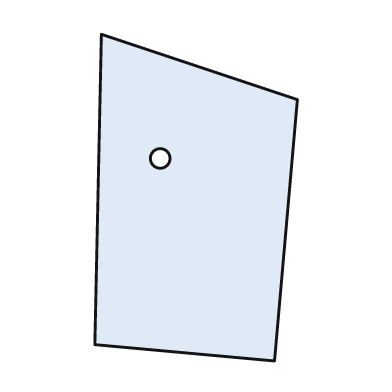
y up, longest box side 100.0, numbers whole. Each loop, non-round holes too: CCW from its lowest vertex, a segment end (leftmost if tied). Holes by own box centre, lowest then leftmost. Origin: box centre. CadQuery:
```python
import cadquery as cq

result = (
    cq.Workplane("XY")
    .moveTo(24.0, -50.0)
    .lineTo(31.0, 30.0)
    .lineTo(-29.0, 50.0)
    .lineTo(-31.0, -45.0)
    .close()
    .moveTo(-11.0, 12.0)
    .circle(3.0)
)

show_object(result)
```